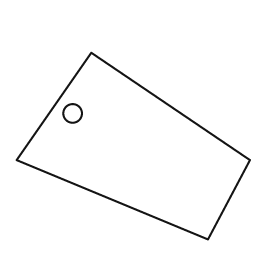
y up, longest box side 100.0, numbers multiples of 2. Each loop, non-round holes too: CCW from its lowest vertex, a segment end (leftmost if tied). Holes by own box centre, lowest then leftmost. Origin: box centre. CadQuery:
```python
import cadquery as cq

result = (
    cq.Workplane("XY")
    .moveTo(32.0, -40.0)
    .lineTo(50.0, -6.0)
    .lineTo(-18.0, 40.0)
    .lineTo(-50.0, -6.0)
    .close()
    .moveTo(-26.0, 14.0)
    .circle(4.0)
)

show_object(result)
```